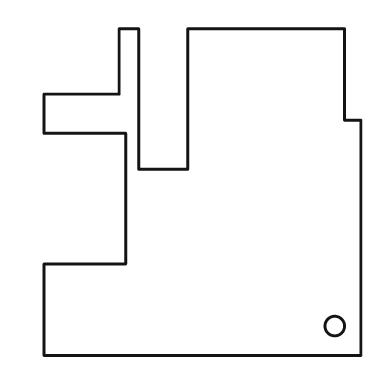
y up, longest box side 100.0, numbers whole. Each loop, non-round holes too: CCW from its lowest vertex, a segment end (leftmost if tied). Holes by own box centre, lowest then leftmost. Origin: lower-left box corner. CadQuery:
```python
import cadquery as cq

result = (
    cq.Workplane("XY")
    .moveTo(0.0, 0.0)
    .lineTo(97.0, 0.0)
    .lineTo(97.0, 72.0)
    .lineTo(92.0, 72.0)
    .lineTo(92.0, 100.0)
    .lineTo(44.0, 100.0)
    .lineTo(44.0, 57.0)
    .lineTo(29.0, 57.0)
    .lineTo(29.0, 100.0)
    .lineTo(23.0, 100.0)
    .lineTo(23.0, 80.0)
    .lineTo(0.0, 80.0)
    .lineTo(0.0, 68.0)
    .lineTo(25.0, 68.0)
    .lineTo(25.0, 28.0)
    .lineTo(0.0, 28.0)
    .close()
    .moveTo(89.0, 9.0)
    .circle(3.0)
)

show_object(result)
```